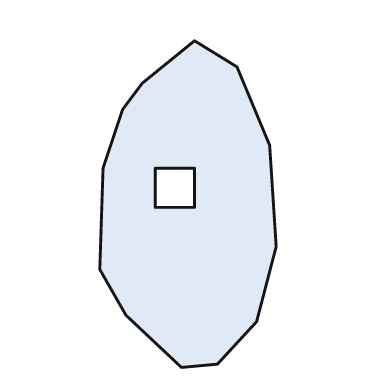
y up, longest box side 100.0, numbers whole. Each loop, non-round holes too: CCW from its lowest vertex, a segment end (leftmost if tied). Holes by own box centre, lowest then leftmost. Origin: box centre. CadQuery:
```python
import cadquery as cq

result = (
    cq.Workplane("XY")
    .moveTo(-2.0, -50.0)
    .lineTo(9.0, -49.0)
    .lineTo(21.0, -36.0)
    .lineTo(27.0, -13.0)
    .lineTo(25.0, 18.0)
    .lineTo(15.0, 42.0)
    .lineTo(2.0, 50.0)
    .lineTo(-14.0, 37.0)
    .lineTo(-20.0, 29.0)
    .lineTo(-26.0, 11.0)
    .lineTo(-27.0, -20.0)
    .lineTo(-19.0, -34.0)
    .close()
    .moveTo(-10.0, -1.0)
    .lineTo(2.0, -1.0)
    .lineTo(2.0, 11.0)
    .lineTo(-10.0, 11.0)
    .close()
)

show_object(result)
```